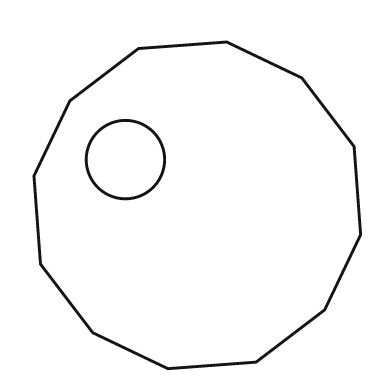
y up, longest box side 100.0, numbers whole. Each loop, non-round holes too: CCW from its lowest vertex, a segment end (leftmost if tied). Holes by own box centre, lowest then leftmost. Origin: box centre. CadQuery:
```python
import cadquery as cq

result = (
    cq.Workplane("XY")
    .moveTo(-9.0, -50.0)
    .lineTo(18.0, -48.0)
    .lineTo(39.0, -32.0)
    .lineTo(50.0, -9.0)
    .lineTo(48.0, 18.0)
    .lineTo(32.0, 39.0)
    .lineTo(9.0, 50.0)
    .lineTo(-18.0, 48.0)
    .lineTo(-39.0, 32.0)
    .lineTo(-50.0, 9.0)
    .lineTo(-48.0, -18.0)
    .lineTo(-32.0, -39.0)
    .close()
    .moveTo(-22.0, 14.0)
    .circle(12.0)
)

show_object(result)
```